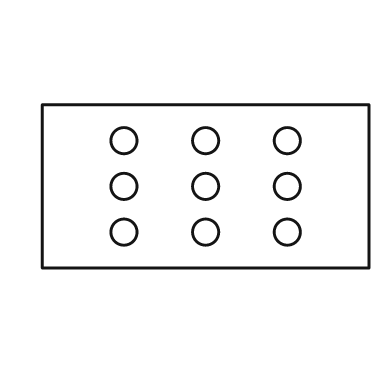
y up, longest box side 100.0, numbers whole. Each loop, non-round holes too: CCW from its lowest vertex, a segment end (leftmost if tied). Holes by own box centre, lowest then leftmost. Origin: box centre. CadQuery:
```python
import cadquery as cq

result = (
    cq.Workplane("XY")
    .moveTo(-50.0, -25.0)
    .lineTo(50.0, -25.0)
    .lineTo(50.0, 25.0)
    .lineTo(-50.0, 25.0)
    .close()
    .moveTo(-25.0, -14.0)
    .circle(4.0)
    .moveTo(0.0, -14.0)
    .circle(4.0)
    .moveTo(25.0, -14.0)
    .circle(4.0)
    .moveTo(-25.0, 0.0)
    .circle(4.0)
    .moveTo(0.0, 0.0)
    .circle(4.0)
    .moveTo(25.0, 0.0)
    .circle(4.0)
    .moveTo(-25.0, 14.0)
    .circle(4.0)
    .moveTo(0.0, 14.0)
    .circle(4.0)
    .moveTo(25.0, 14.0)
    .circle(4.0)
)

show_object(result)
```